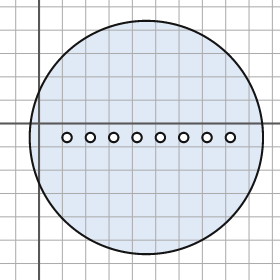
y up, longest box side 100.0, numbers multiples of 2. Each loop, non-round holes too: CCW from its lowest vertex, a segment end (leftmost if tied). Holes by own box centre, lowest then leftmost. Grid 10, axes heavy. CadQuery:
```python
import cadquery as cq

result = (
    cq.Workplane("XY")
    .moveTo(46.0, -6.0)
    .circle(50.0)
    .moveTo(12.0, -6.0)
    .circle(2.0)
    .moveTo(22.0, -6.0)
    .circle(2.0)
    .moveTo(32.0, -6.0)
    .circle(2.0)
    .moveTo(42.0, -6.0)
    .circle(2.0)
    .moveTo(52.0, -6.0)
    .circle(2.0)
    .moveTo(62.0, -6.0)
    .circle(2.0)
    .moveTo(72.0, -6.0)
    .circle(2.0)
    .moveTo(82.0, -6.0)
    .circle(2.0)
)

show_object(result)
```